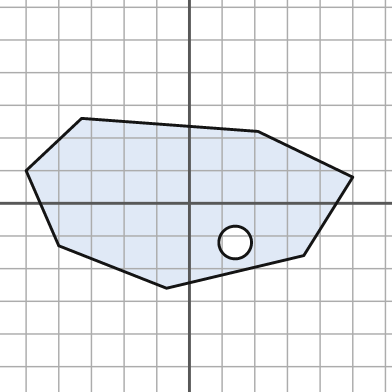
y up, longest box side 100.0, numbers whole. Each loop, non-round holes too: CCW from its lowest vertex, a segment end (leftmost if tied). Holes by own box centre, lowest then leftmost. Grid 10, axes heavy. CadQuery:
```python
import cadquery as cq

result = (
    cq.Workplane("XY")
    .moveTo(-7.0, -26.0)
    .lineTo(35.0, -16.0)
    .lineTo(50.0, 8.0)
    .lineTo(21.0, 22.0)
    .lineTo(-33.0, 26.0)
    .lineTo(-50.0, 10.0)
    .lineTo(-40.0, -13.0)
    .close()
    .moveTo(14.0, -12.0)
    .circle(5.0)
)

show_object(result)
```